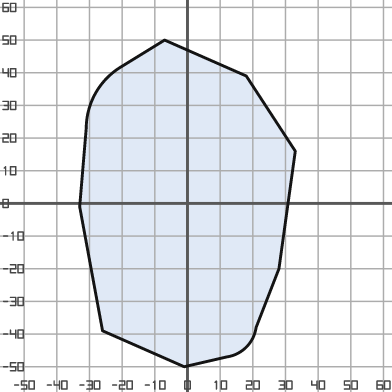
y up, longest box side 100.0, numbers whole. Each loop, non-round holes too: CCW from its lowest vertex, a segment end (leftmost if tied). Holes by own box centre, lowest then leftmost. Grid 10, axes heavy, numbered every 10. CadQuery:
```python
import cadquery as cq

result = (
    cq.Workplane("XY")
    .moveTo(-1.0, -50.0)
    .lineTo(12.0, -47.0)
    .threePointArc((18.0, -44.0), (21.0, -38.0))
    .lineTo(28.0, -20.0)
    .lineTo(33.0, 16.0)
    .lineTo(18.0, 39.0)
    .lineTo(-7.0, 50.0)
    .lineTo(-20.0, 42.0)
    .threePointArc((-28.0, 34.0), (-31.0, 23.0))
    .lineTo(-33.0, -1.0)
    .lineTo(-26.0, -39.0)
    .close()
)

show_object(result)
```